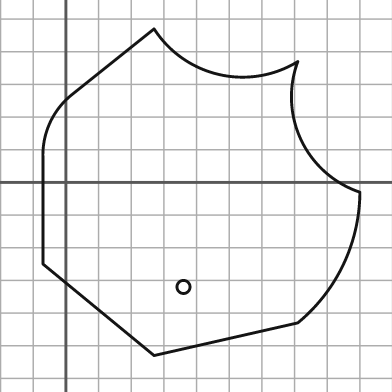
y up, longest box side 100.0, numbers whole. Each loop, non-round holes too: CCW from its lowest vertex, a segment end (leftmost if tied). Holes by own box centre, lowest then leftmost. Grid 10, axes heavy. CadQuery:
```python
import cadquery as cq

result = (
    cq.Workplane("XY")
    .moveTo(27.0, -53.0)
    .lineTo(71.0, -43.0)
    .threePointArc((85.0, -25.0), (90.0, -3.0))
    .threePointArc((72.0, 13.0), (71.0, 37.0))
    .threePointArc((47.0, 33.0), (27.0, 47.0))
    .lineTo(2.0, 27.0)
    .threePointArc((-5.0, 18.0), (-7.0, 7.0))
    .lineTo(-7.0, -25.0)
    .close()
    .moveTo(36.0, -32.0)
    .circle(2.0)
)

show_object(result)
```